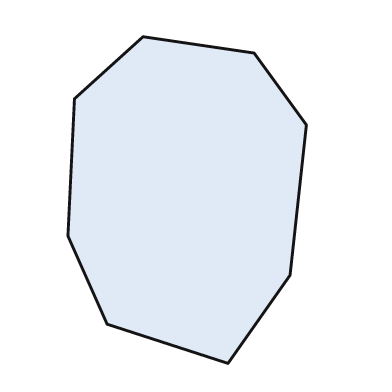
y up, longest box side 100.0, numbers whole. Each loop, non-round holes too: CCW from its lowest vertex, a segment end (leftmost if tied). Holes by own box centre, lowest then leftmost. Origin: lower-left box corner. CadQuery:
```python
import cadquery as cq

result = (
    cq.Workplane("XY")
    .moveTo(49.0, 0.0)
    .lineTo(68.0, 27.0)
    .lineTo(73.0, 73.0)
    .lineTo(57.0, 95.0)
    .lineTo(23.0, 100.0)
    .lineTo(2.0, 81.0)
    .lineTo(0.0, 39.0)
    .lineTo(12.0, 12.0)
    .close()
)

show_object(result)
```